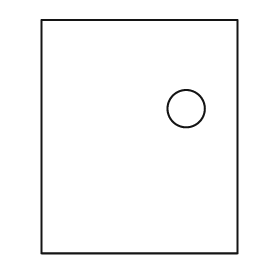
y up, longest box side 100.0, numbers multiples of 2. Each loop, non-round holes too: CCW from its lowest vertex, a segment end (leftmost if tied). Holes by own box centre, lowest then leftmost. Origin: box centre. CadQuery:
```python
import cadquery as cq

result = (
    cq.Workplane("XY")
    .moveTo(-42.0, -50.0)
    .lineTo(42.0, -50.0)
    .lineTo(42.0, 50.0)
    .lineTo(-42.0, 50.0)
    .close()
    .moveTo(20.0, 12.0)
    .circle(8.0)
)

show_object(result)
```